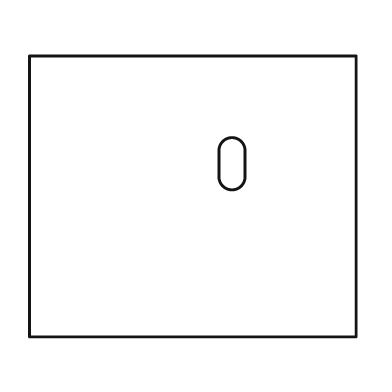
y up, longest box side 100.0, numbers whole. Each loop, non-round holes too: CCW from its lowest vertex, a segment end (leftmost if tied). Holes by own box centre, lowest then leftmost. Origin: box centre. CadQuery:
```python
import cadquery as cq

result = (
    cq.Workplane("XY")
    .moveTo(-50.0, -43.0)
    .lineTo(50.0, -43.0)
    .lineTo(50.0, 43.0)
    .lineTo(-50.0, 43.0)
    .close()
    .moveTo(8.0, 6.0)
    .threePointArc((12.0, 2.0), (16.0, 6.0))
    .lineTo(16.0, 14.0)
    .threePointArc((12.0, 18.0), (8.0, 14.0))
    .close()
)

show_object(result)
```